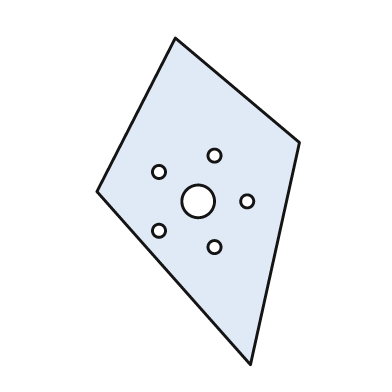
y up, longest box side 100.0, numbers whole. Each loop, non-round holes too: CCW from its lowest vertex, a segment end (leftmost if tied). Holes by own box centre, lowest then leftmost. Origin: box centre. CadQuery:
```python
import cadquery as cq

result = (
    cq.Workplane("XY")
    .moveTo(16.0, -50.0)
    .lineTo(31.0, 18.0)
    .lineTo(-7.0, 50.0)
    .lineTo(-31.0, 3.0)
    .close()
    .moveTo(5.0, -14.0)
    .circle(2.0)
    .moveTo(-12.0, -9.0)
    .circle(2.0)
    .moveTo(0.0, 0.0)
    .circle(5.0)
    .moveTo(15.0, 0.0)
    .circle(2.0)
    .moveTo(-12.0, 9.0)
    .circle(2.0)
    .moveTo(5.0, 14.0)
    .circle(2.0)
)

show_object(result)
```